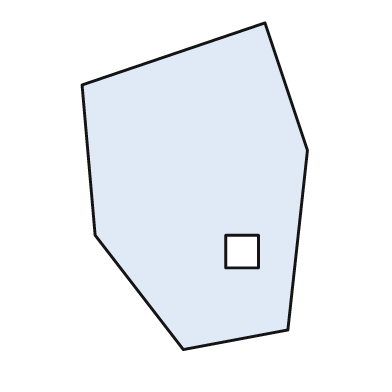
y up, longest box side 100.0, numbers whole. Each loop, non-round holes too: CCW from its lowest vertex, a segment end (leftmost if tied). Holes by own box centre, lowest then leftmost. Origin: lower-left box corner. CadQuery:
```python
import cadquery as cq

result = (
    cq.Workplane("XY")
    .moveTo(31.0, 0.0)
    .lineTo(63.0, 6.0)
    .lineTo(69.0, 61.0)
    .lineTo(56.0, 100.0)
    .lineTo(0.0, 81.0)
    .lineTo(4.0, 35.0)
    .close()
    .moveTo(44.0, 25.0)
    .lineTo(54.0, 25.0)
    .lineTo(54.0, 35.0)
    .lineTo(44.0, 35.0)
    .close()
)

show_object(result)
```